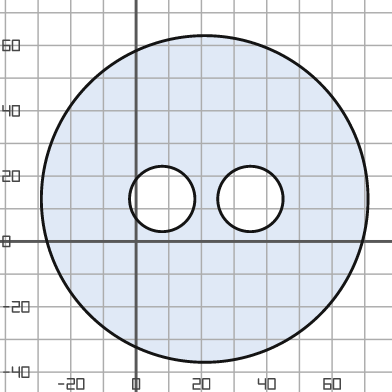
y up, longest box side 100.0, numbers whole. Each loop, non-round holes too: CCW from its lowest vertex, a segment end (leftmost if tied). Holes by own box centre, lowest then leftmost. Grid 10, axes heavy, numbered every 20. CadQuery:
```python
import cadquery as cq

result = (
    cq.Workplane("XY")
    .moveTo(21.0, 13.0)
    .circle(50.0)
    .moveTo(8.0, 13.0)
    .circle(10.0)
    .moveTo(35.0, 13.0)
    .circle(10.0)
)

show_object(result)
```